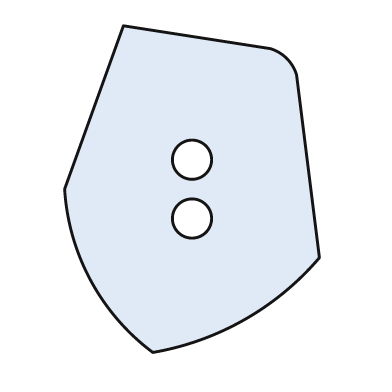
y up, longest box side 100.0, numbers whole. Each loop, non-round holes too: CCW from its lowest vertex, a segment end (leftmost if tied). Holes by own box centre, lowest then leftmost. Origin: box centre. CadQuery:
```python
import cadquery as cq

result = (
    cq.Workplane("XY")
    .moveTo(-12.0, -50.0)
    .threePointArc((16.0, -40.0), (39.0, -21.0))
    .lineTo(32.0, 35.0)
    .threePointArc((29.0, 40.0), (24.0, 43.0))
    .lineTo(-21.0, 50.0)
    .lineTo(-39.0, 0.0)
    .threePointArc((-31.0, -28.0), (-12.0, -50.0))
    .close()
    .moveTo(0.0, -9.0)
    .circle(6.0)
    .moveTo(0.0, 9.0)
    .circle(6.0)
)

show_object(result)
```